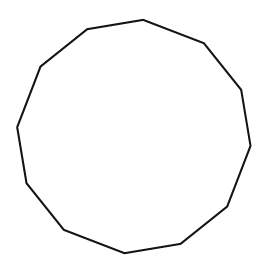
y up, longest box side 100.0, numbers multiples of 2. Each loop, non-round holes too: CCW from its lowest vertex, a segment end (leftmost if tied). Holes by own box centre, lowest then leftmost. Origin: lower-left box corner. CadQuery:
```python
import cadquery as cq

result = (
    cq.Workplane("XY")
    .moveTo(46.0, 0.0)
    .lineTo(70.0, 4.0)
    .lineTo(90.0, 20.0)
    .lineTo(100.0, 46.0)
    .lineTo(96.0, 70.0)
    .lineTo(80.0, 90.0)
    .lineTo(54.0, 100.0)
    .lineTo(30.0, 96.0)
    .lineTo(10.0, 80.0)
    .lineTo(0.0, 54.0)
    .lineTo(4.0, 30.0)
    .lineTo(20.0, 10.0)
    .close()
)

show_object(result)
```